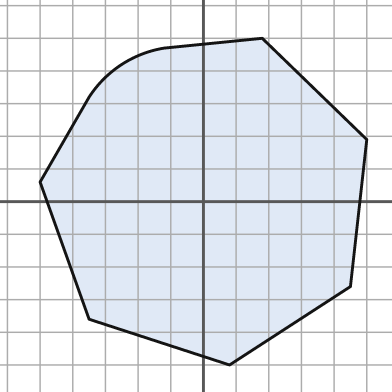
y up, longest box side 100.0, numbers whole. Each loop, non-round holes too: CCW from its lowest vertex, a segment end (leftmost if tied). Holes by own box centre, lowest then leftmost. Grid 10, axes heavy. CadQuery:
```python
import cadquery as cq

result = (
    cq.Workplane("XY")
    .moveTo(8.0, -50.0)
    .lineTo(45.0, -26.0)
    .lineTo(50.0, 19.0)
    .lineTo(18.0, 50.0)
    .lineTo(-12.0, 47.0)
    .threePointArc((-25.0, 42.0), (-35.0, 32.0))
    .lineTo(-50.0, 6.0)
    .lineTo(-35.0, -36.0)
    .close()
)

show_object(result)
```